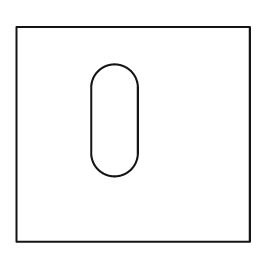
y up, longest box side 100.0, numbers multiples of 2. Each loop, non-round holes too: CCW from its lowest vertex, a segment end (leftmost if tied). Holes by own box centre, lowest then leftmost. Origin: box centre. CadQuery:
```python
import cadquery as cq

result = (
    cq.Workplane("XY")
    .moveTo(-50.0, -46.0)
    .lineTo(50.0, -46.0)
    .lineTo(50.0, 46.0)
    .lineTo(-50.0, 46.0)
    .close()
    .moveTo(-18.0, -8.0)
    .threePointArc((-8.0, -18.0), (2.0, -8.0))
    .lineTo(2.0, 20.0)
    .threePointArc((-8.0, 30.0), (-18.0, 20.0))
    .close()
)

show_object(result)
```